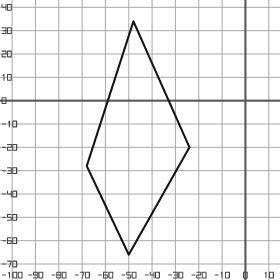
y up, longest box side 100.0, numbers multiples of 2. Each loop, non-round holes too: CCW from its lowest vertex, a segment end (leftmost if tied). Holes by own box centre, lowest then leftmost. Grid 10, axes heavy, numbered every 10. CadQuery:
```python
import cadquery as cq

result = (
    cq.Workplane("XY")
    .moveTo(-50.0, -66.0)
    .lineTo(-24.0, -20.0)
    .lineTo(-48.0, 34.0)
    .lineTo(-68.0, -28.0)
    .close()
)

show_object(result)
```